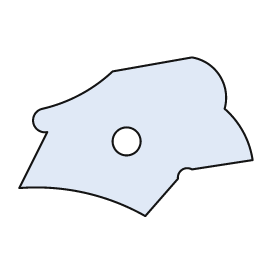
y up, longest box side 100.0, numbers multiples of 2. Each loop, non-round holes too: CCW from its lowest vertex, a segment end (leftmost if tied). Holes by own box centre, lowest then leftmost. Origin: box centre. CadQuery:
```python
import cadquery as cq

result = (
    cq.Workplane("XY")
    .moveTo(4.0, -34.0)
    .lineTo(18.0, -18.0)
    .threePointArc((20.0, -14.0), (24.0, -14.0))
    .lineTo(50.0, -10.0)
    .threePointArc((46.0, 2.0), (38.0, 12.0))
    .threePointArc((36.0, 26.0), (24.0, 34.0))
    .lineTo(-10.0, 28.0)
    .threePointArc((-24.0, 18.0), (-40.0, 12.0))
    .threePointArc((-44.0, 6.0), (-38.0, 2.0))
    .lineTo(-50.0, -22.0)
    .threePointArc((-22.0, -24.0), (4.0, -34.0))
    .close()
    .moveTo(-4.0, -2.0)
    .circle(6.0)
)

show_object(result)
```